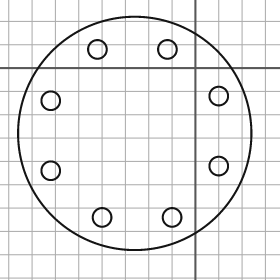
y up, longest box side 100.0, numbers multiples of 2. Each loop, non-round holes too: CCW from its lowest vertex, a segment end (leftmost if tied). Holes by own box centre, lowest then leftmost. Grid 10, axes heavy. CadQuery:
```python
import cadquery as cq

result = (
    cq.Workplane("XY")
    .moveTo(-26.0, -28.0)
    .circle(50.0)
    .moveTo(-40.0, -64.0)
    .circle(4.0)
    .moveTo(-10.0, -64.0)
    .circle(4.0)
    .moveTo(-62.0, -44.0)
    .circle(4.0)
    .moveTo(10.0, -42.0)
    .circle(4.0)
    .moveTo(-62.0, -14.0)
    .circle(4.0)
    .moveTo(10.0, -12.0)
    .circle(4.0)
    .moveTo(-42.0, 8.0)
    .circle(4.0)
    .moveTo(-12.0, 8.0)
    .circle(4.0)
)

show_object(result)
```